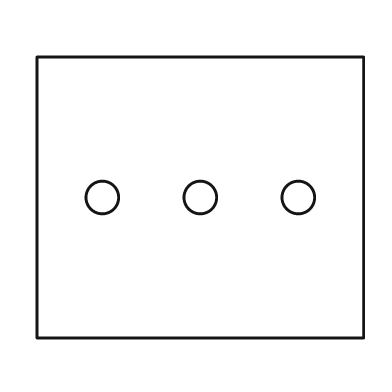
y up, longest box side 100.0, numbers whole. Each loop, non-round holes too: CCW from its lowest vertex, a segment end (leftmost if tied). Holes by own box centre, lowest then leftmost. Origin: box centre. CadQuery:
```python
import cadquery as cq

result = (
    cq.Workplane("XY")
    .moveTo(-50.0, -43.0)
    .lineTo(50.0, -43.0)
    .lineTo(50.0, 43.0)
    .lineTo(-50.0, 43.0)
    .close()
    .moveTo(-30.0, 0.0)
    .circle(5.0)
    .moveTo(0.0, 0.0)
    .circle(5.0)
    .moveTo(30.0, 0.0)
    .circle(5.0)
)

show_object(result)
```